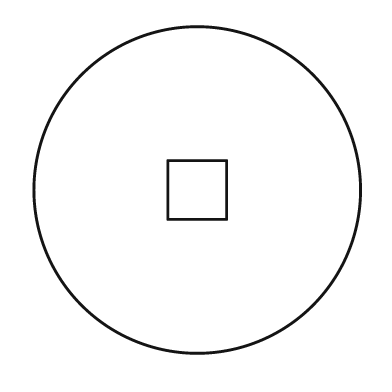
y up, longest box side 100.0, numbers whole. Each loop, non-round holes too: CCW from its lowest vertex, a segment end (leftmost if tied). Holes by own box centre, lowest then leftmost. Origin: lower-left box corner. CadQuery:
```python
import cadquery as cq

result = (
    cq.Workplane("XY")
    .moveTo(50.0, 50.0)
    .circle(50.0)
    .moveTo(41.0, 41.0)
    .lineTo(59.0, 41.0)
    .lineTo(59.0, 59.0)
    .lineTo(41.0, 59.0)
    .close()
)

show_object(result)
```